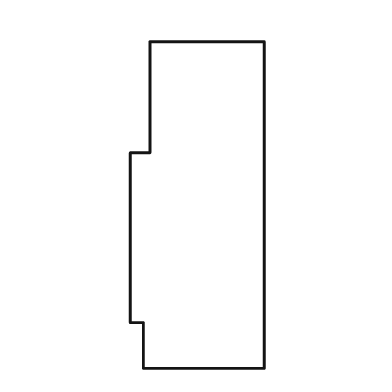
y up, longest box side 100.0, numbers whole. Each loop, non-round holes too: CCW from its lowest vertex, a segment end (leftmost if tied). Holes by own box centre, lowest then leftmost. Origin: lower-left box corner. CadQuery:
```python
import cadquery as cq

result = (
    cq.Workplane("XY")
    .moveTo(4.0, 0.0)
    .lineTo(41.0, 0.0)
    .lineTo(41.0, 100.0)
    .lineTo(6.0, 100.0)
    .lineTo(6.0, 66.0)
    .lineTo(0.0, 66.0)
    .lineTo(0.0, 14.0)
    .lineTo(4.0, 14.0)
    .close()
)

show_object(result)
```